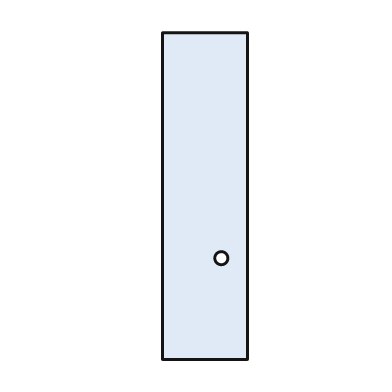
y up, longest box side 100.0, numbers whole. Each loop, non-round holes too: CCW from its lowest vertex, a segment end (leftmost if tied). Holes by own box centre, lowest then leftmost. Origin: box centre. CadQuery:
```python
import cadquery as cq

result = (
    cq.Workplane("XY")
    .moveTo(-13.0, -50.0)
    .lineTo(13.0, -50.0)
    .lineTo(13.0, 50.0)
    .lineTo(-13.0, 50.0)
    .close()
    .moveTo(5.0, -19.0)
    .circle(2.0)
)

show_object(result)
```